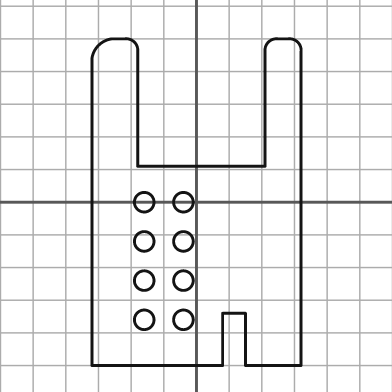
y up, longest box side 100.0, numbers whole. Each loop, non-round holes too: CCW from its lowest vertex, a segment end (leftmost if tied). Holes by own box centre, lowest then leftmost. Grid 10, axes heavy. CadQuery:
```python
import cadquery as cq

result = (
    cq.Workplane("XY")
    .moveTo(-32.0, -50.0)
    .lineTo(8.0, -50.0)
    .lineTo(8.0, -34.0)
    .lineTo(15.0, -34.0)
    .lineTo(15.0, -50.0)
    .lineTo(32.0, -50.0)
    .lineTo(32.0, 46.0)
    .threePointArc((31.0, 49.0), (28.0, 50.0))
    .lineTo(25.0, 50.0)
    .threePointArc((22.0, 49.0), (21.0, 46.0))
    .lineTo(21.0, 11.0)
    .lineTo(-18.0, 11.0)
    .lineTo(-18.0, 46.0)
    .threePointArc((-19.0, 49.0), (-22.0, 50.0))
    .lineTo(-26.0, 50.0)
    .threePointArc((-30.0, 48.0), (-32.0, 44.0))
    .close()
    .moveTo(-16.0, -36.0)
    .circle(3.0)
    .moveTo(-4.0, -36.0)
    .circle(3.0)
    .moveTo(-16.0, -24.0)
    .circle(3.0)
    .moveTo(-4.0, -24.0)
    .circle(3.0)
    .moveTo(-16.0, -12.0)
    .circle(3.0)
    .moveTo(-4.0, -12.0)
    .circle(3.0)
    .moveTo(-16.0, 0.0)
    .circle(3.0)
    .moveTo(-4.0, 0.0)
    .circle(3.0)
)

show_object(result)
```